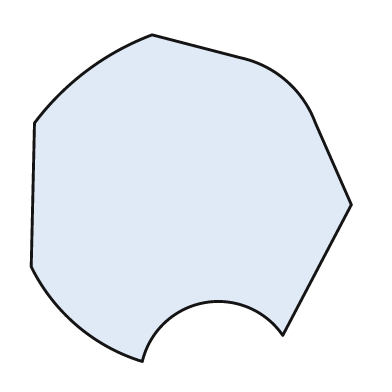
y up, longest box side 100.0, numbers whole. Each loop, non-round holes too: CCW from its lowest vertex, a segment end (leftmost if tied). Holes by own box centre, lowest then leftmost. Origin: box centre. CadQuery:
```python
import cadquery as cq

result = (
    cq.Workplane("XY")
    .moveTo(-15.0, -50.0)
    .threePointArc((4.0, -32.0), (28.0, -42.0))
    .lineTo(49.0, -2.0)
    .lineTo(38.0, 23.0)
    .threePointArc((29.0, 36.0), (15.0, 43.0))
    .lineTo(-12.0, 50.0)
    .threePointArc((-32.0, 39.0), (-48.0, 23.0))
    .lineTo(-49.0, -21.0)
    .threePointArc((-35.0, -39.0), (-15.0, -50.0))
    .close()
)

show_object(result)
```